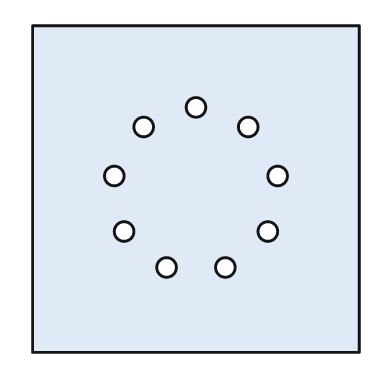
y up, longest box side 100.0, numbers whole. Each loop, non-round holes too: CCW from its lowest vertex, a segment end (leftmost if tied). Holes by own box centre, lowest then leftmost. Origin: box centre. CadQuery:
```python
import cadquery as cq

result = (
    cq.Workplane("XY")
    .moveTo(-50.0, -50.0)
    .lineTo(50.0, -50.0)
    .lineTo(50.0, 50.0)
    .lineTo(-50.0, 50.0)
    .close()
    .moveTo(-9.0, -24.0)
    .circle(3.0)
    .moveTo(9.0, -24.0)
    .circle(3.0)
    .moveTo(-22.0, -13.0)
    .circle(3.0)
    .moveTo(22.0, -13.0)
    .circle(3.0)
    .moveTo(-25.0, 4.0)
    .circle(3.0)
    .moveTo(25.0, 4.0)
    .circle(3.0)
    .moveTo(-16.0, 19.0)
    .circle(3.0)
    .moveTo(16.0, 19.0)
    .circle(3.0)
    .moveTo(0.0, 25.0)
    .circle(3.0)
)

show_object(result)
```